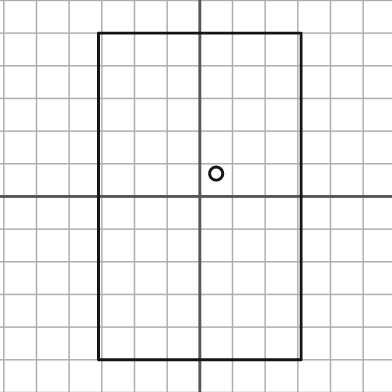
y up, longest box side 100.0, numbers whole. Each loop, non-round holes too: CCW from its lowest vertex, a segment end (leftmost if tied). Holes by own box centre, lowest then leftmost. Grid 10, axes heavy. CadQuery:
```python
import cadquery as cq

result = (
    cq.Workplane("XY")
    .moveTo(-31.0, -50.0)
    .lineTo(31.0, -50.0)
    .lineTo(31.0, 50.0)
    .lineTo(-31.0, 50.0)
    .close()
    .moveTo(5.0, 7.0)
    .circle(2.0)
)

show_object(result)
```